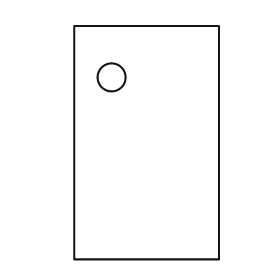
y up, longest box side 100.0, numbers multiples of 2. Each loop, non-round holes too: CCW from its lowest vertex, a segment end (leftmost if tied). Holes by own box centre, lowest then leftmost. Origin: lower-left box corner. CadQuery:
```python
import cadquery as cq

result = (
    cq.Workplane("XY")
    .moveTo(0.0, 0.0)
    .lineTo(62.0, 0.0)
    .lineTo(62.0, 100.0)
    .lineTo(0.0, 100.0)
    .close()
    .moveTo(16.0, 78.0)
    .circle(6.0)
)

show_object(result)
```